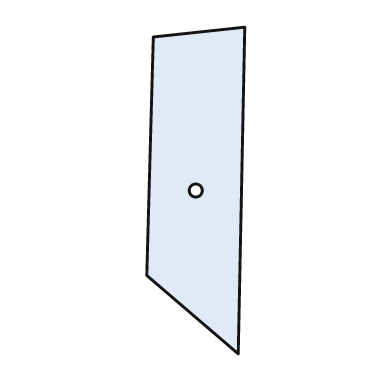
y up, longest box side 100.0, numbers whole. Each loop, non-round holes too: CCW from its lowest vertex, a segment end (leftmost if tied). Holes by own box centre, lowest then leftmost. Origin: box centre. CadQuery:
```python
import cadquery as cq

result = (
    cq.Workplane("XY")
    .moveTo(13.0, -50.0)
    .lineTo(15.0, 50.0)
    .lineTo(-13.0, 47.0)
    .lineTo(-15.0, -26.0)
    .close()
    .moveTo(0.0, 0.0)
    .circle(2.0)
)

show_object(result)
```